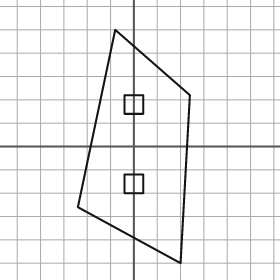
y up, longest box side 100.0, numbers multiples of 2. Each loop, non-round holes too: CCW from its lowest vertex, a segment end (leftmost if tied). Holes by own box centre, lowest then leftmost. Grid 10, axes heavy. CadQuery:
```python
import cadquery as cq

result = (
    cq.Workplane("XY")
    .moveTo(20.0, -50.0)
    .lineTo(24.0, 22.0)
    .lineTo(-8.0, 50.0)
    .lineTo(-24.0, -26.0)
    .close()
    .moveTo(-4.0, -20.0)
    .lineTo(4.0, -20.0)
    .lineTo(4.0, -12.0)
    .lineTo(-4.0, -12.0)
    .close()
    .moveTo(-4.0, 14.0)
    .lineTo(4.0, 14.0)
    .lineTo(4.0, 22.0)
    .lineTo(-4.0, 22.0)
    .close()
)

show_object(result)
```